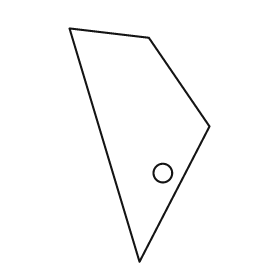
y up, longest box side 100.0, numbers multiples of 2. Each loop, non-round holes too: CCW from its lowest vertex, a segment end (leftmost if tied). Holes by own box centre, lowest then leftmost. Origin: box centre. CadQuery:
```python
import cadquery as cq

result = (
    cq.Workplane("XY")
    .moveTo(0.0, -50.0)
    .lineTo(30.0, 8.0)
    .lineTo(4.0, 46.0)
    .lineTo(-30.0, 50.0)
    .close()
    .moveTo(10.0, -12.0)
    .circle(4.0)
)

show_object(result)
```